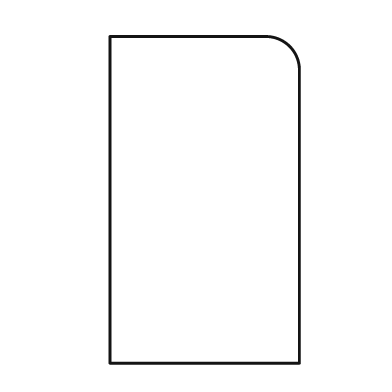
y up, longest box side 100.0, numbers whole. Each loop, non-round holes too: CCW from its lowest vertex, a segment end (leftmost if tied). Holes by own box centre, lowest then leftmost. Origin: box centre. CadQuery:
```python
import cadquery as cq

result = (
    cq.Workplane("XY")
    .moveTo(-29.0, -50.0)
    .lineTo(29.0, -50.0)
    .lineTo(29.0, 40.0)
    .threePointArc((26.0, 47.0), (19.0, 50.0))
    .lineTo(-29.0, 50.0)
    .close()
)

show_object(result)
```